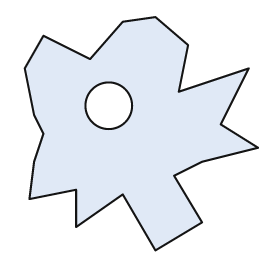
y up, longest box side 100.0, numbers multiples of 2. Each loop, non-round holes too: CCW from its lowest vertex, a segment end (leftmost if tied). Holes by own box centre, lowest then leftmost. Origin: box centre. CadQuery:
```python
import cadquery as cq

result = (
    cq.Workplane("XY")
    .moveTo(6.0, -50.0)
    .lineTo(26.0, -38.0)
    .lineTo(14.0, -18.0)
    .lineTo(26.0, -12.0)
    .lineTo(50.0, -6.0)
    .lineTo(34.0, 4.0)
    .lineTo(46.0, 28.0)
    .lineTo(16.0, 18.0)
    .lineTo(20.0, 38.0)
    .lineTo(6.0, 50.0)
    .lineTo(-8.0, 48.0)
    .lineTo(-22.0, 32.0)
    .lineTo(-42.0, 42.0)
    .lineTo(-50.0, 28.0)
    .lineTo(-46.0, 8.0)
    .lineTo(-42.0, 0.0)
    .lineTo(-46.0, -12.0)
    .lineTo(-48.0, -28.0)
    .lineTo(-28.0, -24.0)
    .lineTo(-28.0, -40.0)
    .lineTo(-8.0, -26.0)
    .close()
    .moveTo(-14.0, 12.0)
    .circle(10.0)
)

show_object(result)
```